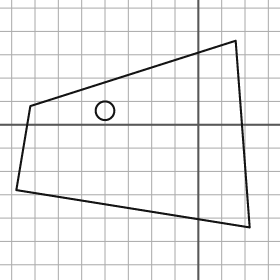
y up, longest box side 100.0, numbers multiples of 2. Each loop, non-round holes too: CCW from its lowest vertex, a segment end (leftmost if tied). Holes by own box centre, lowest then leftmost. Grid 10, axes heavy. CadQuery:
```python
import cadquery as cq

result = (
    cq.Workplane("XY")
    .moveTo(22.0, -44.0)
    .lineTo(16.0, 36.0)
    .lineTo(-72.0, 8.0)
    .lineTo(-78.0, -28.0)
    .close()
    .moveTo(-40.0, 6.0)
    .circle(4.0)
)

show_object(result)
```